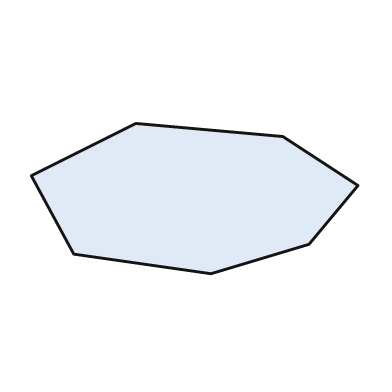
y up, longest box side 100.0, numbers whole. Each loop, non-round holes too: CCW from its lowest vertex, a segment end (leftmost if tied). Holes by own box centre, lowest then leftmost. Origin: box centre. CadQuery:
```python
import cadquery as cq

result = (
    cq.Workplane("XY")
    .moveTo(5.0, -23.0)
    .lineTo(35.0, -14.0)
    .lineTo(50.0, 4.0)
    .lineTo(27.0, 19.0)
    .lineTo(-18.0, 23.0)
    .lineTo(-50.0, 7.0)
    .lineTo(-37.0, -17.0)
    .close()
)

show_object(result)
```